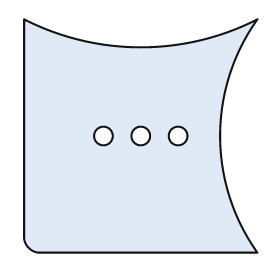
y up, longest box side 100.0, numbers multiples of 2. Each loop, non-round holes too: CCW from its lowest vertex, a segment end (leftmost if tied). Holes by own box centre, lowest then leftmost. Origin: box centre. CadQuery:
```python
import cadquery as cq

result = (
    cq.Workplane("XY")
    .moveTo(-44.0, -50.0)
    .lineTo(50.0, -50.0)
    .threePointArc((34.0, 0.0), (50.0, 50.0))
    .threePointArc((0.0, 38.0), (-50.0, 50.0))
    .lineTo(-50.0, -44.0)
    .threePointArc((-48.0, -48.0), (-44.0, -50.0))
    .close()
    .moveTo(-16.0, 0.0)
    .circle(4.0)
    .moveTo(0.0, 0.0)
    .circle(4.0)
    .moveTo(16.0, 0.0)
    .circle(4.0)
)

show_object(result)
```